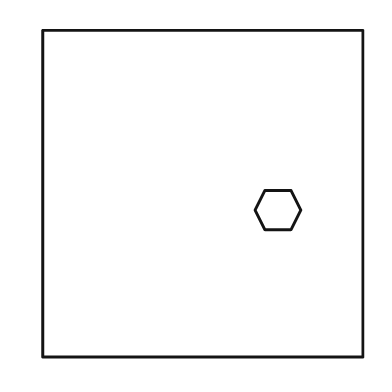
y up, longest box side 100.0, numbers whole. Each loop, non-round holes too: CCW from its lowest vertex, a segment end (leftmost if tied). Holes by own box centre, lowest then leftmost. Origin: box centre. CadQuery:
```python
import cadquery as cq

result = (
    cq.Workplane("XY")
    .moveTo(-49.0, -50.0)
    .lineTo(49.0, -50.0)
    .lineTo(49.0, 50.0)
    .lineTo(-49.0, 50.0)
    .close()
    .moveTo(19.0, -11.0)
    .lineTo(27.0, -11.0)
    .lineTo(30.0, -5.0)
    .lineTo(27.0, 1.0)
    .lineTo(19.0, 1.0)
    .lineTo(16.0, -5.0)
    .close()
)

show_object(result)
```